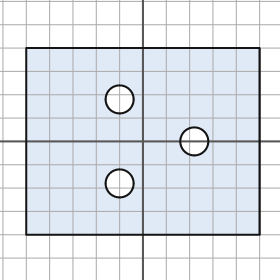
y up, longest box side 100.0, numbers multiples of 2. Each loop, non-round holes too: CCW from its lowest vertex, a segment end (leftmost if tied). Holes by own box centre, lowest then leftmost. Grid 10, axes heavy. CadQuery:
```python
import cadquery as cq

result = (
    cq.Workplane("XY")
    .moveTo(-50.0, -40.0)
    .lineTo(50.0, -40.0)
    .lineTo(50.0, 40.0)
    .lineTo(-50.0, 40.0)
    .close()
    .moveTo(-10.0, -18.0)
    .circle(6.0)
    .moveTo(22.0, 0.0)
    .circle(6.0)
    .moveTo(-10.0, 18.0)
    .circle(6.0)
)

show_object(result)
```